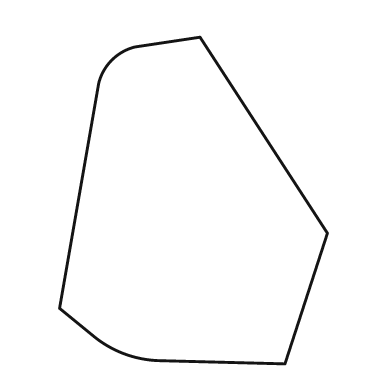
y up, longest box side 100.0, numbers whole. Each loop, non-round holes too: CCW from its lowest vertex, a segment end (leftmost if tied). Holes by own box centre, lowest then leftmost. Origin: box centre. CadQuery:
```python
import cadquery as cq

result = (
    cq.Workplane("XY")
    .moveTo(28.0, -50.0)
    .lineTo(41.0, -10.0)
    .lineTo(2.0, 50.0)
    .lineTo(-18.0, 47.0)
    .threePointArc((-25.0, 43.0), (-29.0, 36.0))
    .lineTo(-41.0, -33.0)
    .lineTo(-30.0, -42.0)
    .threePointArc((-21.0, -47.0), (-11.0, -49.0))
    .close()
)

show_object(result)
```